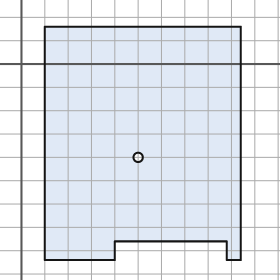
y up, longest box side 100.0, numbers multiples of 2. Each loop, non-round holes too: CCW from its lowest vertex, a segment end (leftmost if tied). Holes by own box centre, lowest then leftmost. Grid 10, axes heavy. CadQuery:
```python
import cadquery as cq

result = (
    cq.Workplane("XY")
    .moveTo(10.0, -84.0)
    .lineTo(40.0, -84.0)
    .lineTo(40.0, -76.0)
    .lineTo(88.0, -76.0)
    .lineTo(88.0, -84.0)
    .lineTo(94.0, -84.0)
    .lineTo(94.0, 16.0)
    .lineTo(10.0, 16.0)
    .close()
    .moveTo(50.0, -40.0)
    .circle(2.0)
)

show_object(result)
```